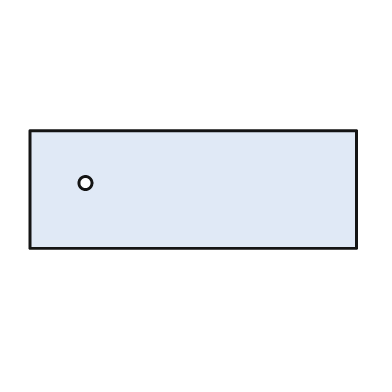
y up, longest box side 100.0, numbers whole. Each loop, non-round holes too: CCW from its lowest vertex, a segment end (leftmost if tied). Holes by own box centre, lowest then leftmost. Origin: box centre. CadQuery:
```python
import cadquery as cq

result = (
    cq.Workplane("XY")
    .moveTo(-50.0, -18.0)
    .lineTo(50.0, -18.0)
    .lineTo(50.0, 18.0)
    .lineTo(-50.0, 18.0)
    .close()
    .moveTo(-33.0, 2.0)
    .circle(2.0)
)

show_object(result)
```